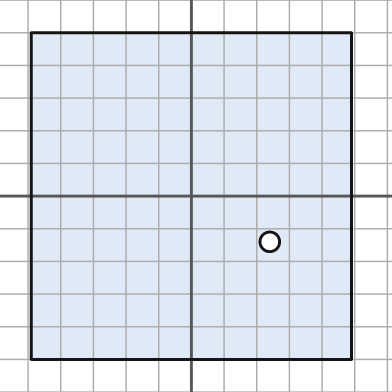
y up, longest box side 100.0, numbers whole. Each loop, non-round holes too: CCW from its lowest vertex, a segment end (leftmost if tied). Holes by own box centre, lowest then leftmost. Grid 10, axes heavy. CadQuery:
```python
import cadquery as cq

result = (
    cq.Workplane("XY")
    .moveTo(-49.0, -50.0)
    .lineTo(49.0, -50.0)
    .lineTo(49.0, 50.0)
    .lineTo(-49.0, 50.0)
    .close()
    .moveTo(24.0, -14.0)
    .circle(3.0)
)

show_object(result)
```